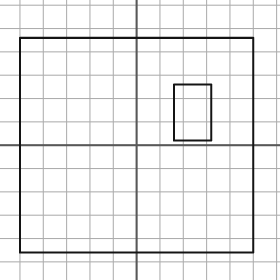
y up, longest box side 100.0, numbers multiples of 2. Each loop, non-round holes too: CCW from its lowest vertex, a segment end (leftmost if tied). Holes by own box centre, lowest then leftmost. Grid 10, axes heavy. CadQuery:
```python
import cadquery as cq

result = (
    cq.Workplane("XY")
    .moveTo(-50.0, -46.0)
    .lineTo(50.0, -46.0)
    .lineTo(50.0, 46.0)
    .lineTo(-50.0, 46.0)
    .close()
    .moveTo(16.0, 2.0)
    .lineTo(32.0, 2.0)
    .lineTo(32.0, 26.0)
    .lineTo(16.0, 26.0)
    .close()
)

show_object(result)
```